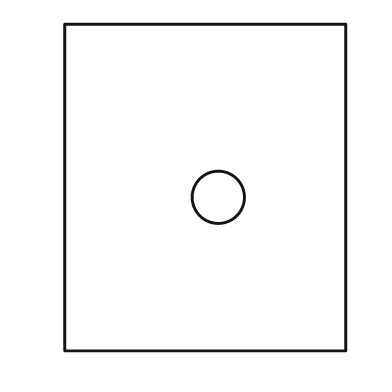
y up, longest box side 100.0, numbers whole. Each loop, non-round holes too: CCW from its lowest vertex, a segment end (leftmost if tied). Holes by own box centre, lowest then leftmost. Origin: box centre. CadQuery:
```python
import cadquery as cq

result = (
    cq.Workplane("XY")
    .moveTo(-43.0, -50.0)
    .lineTo(43.0, -50.0)
    .lineTo(43.0, 50.0)
    .lineTo(-43.0, 50.0)
    .close()
    .moveTo(4.0, -3.0)
    .circle(8.0)
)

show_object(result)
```